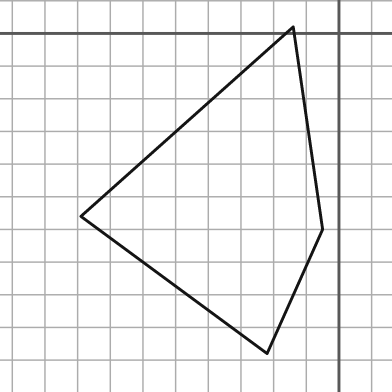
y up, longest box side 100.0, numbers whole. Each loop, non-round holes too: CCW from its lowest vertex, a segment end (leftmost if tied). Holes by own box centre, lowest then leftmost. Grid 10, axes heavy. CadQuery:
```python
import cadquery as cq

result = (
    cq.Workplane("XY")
    .moveTo(-22.0, -98.0)
    .lineTo(-5.0, -60.0)
    .lineTo(-14.0, 2.0)
    .lineTo(-79.0, -56.0)
    .close()
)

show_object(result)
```